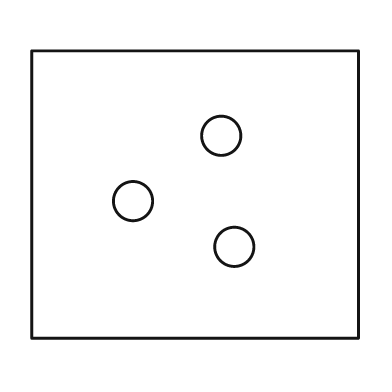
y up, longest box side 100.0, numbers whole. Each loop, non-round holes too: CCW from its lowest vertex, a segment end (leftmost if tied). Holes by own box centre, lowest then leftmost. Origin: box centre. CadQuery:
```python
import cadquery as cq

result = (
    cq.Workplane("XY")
    .moveTo(-50.0, -44.0)
    .lineTo(50.0, -44.0)
    .lineTo(50.0, 44.0)
    .lineTo(-50.0, 44.0)
    .close()
    .moveTo(12.0, -16.0)
    .circle(6.0)
    .moveTo(-19.0, -2.0)
    .circle(6.0)
    .moveTo(8.0, 18.0)
    .circle(6.0)
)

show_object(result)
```